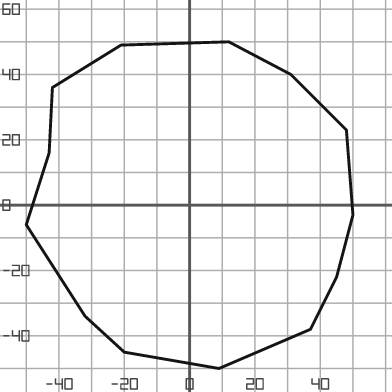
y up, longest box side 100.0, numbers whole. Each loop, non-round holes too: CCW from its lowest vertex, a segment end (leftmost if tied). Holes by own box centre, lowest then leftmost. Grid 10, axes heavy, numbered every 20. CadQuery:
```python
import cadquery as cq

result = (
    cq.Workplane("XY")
    .moveTo(9.0, -50.0)
    .lineTo(37.0, -38.0)
    .lineTo(45.0, -22.0)
    .lineTo(50.0, -3.0)
    .lineTo(48.0, 23.0)
    .lineTo(31.0, 40.0)
    .lineTo(12.0, 50.0)
    .lineTo(-21.0, 49.0)
    .lineTo(-42.0, 36.0)
    .lineTo(-43.0, 16.0)
    .lineTo(-50.0, -6.0)
    .lineTo(-32.0, -34.0)
    .lineTo(-20.0, -45.0)
    .close()
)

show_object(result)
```